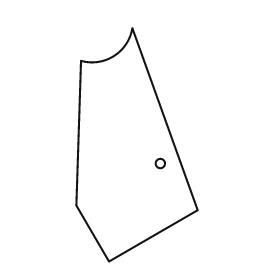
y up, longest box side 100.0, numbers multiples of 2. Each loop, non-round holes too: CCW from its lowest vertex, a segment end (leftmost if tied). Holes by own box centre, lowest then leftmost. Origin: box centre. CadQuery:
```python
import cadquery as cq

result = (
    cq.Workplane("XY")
    .moveTo(-12.0, -50.0)
    .lineTo(26.0, -28.0)
    .lineTo(-2.0, 50.0)
    .threePointArc((-10.0, 38.0), (-24.0, 36.0))
    .lineTo(-26.0, -26.0)
    .close()
    .moveTo(10.0, -8.0)
    .circle(2.0)
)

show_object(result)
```